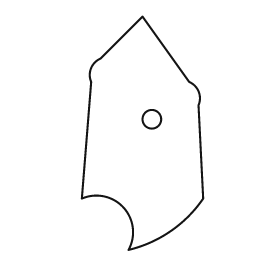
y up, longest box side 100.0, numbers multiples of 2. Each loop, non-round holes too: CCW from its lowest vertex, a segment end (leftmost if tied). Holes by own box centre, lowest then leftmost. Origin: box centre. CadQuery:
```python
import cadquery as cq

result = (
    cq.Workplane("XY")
    .moveTo(-6.0, -50.0)
    .threePointArc((12.0, -42.0), (26.0, -28.0))
    .lineTo(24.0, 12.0)
    .threePointArc((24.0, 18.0), (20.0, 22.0))
    .lineTo(0.0, 50.0)
    .lineTo(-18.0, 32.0)
    .threePointArc((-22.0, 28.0), (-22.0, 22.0))
    .lineTo(-26.0, -28.0)
    .threePointArc((-8.0, -32.0), (-6.0, -50.0))
    .close()
    .moveTo(4.0, 6.0)
    .circle(4.0)
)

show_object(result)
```